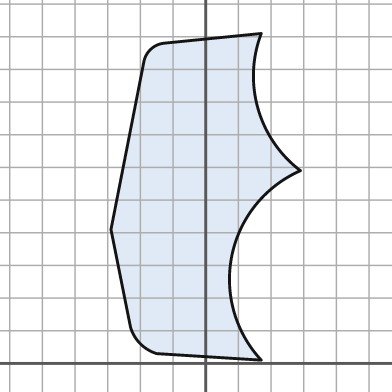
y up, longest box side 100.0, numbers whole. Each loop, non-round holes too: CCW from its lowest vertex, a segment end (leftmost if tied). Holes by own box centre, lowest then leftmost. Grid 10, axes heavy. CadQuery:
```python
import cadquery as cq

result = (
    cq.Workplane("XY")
    .moveTo(17.0, 1.0)
    .threePointArc((8.0, 33.0), (29.0, 59.0))
    .threePointArc((16.0, 78.0), (17.0, 101.0))
    .lineTo(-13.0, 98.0)
    .threePointArc((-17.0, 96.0), (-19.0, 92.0))
    .lineTo(-29.0, 41.0)
    .lineTo(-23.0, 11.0)
    .threePointArc((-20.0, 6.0), (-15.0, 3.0))
    .close()
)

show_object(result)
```